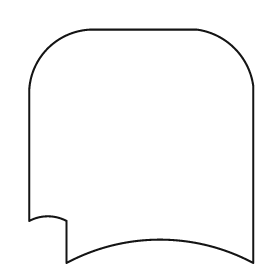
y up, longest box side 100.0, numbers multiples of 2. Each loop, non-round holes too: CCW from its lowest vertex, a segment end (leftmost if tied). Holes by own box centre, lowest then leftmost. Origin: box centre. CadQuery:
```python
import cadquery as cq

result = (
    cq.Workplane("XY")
    .moveTo(-32.0, -50.0)
    .threePointArc((8.0, -40.0), (48.0, -50.0))
    .lineTo(48.0, 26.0)
    .threePointArc((40.0, 42.0), (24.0, 50.0))
    .lineTo(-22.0, 50.0)
    .threePointArc((-40.0, 42.0), (-48.0, 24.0))
    .lineTo(-48.0, -32.0)
    .threePointArc((-40.0, -30.0), (-32.0, -32.0))
    .close()
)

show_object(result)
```